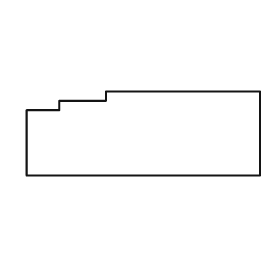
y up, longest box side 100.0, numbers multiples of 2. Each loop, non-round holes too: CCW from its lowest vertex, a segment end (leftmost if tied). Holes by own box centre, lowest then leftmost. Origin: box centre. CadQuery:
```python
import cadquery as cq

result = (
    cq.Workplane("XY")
    .moveTo(-50.0, -18.0)
    .lineTo(50.0, -18.0)
    .lineTo(50.0, 18.0)
    .lineTo(-16.0, 18.0)
    .lineTo(-16.0, 14.0)
    .lineTo(-36.0, 14.0)
    .lineTo(-36.0, 10.0)
    .lineTo(-50.0, 10.0)
    .close()
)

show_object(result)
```